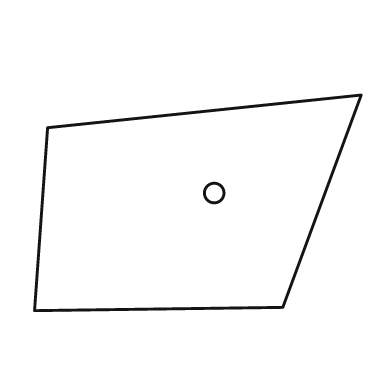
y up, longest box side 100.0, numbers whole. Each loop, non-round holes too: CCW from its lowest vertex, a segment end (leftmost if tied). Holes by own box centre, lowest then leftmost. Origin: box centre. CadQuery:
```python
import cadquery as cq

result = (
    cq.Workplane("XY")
    .moveTo(-50.0, -33.0)
    .lineTo(26.0, -32.0)
    .lineTo(50.0, 33.0)
    .lineTo(-46.0, 23.0)
    .close()
    .moveTo(5.0, 3.0)
    .circle(3.0)
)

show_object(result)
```